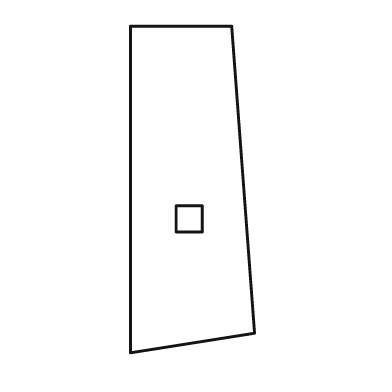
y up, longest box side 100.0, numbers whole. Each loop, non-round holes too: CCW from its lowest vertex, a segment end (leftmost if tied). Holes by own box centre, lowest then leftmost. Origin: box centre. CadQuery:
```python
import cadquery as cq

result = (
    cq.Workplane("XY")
    .moveTo(-19.0, -50.0)
    .lineTo(19.0, -44.0)
    .lineTo(12.0, 50.0)
    .lineTo(-19.0, 50.0)
    .close()
    .moveTo(-5.0, -13.0)
    .lineTo(3.0, -13.0)
    .lineTo(3.0, -5.0)
    .lineTo(-5.0, -5.0)
    .close()
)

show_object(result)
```